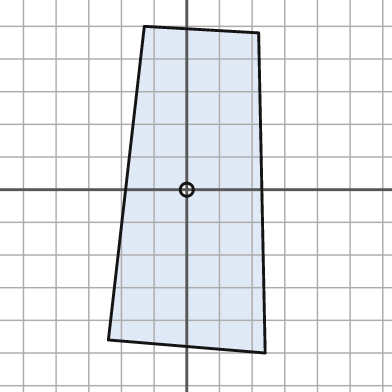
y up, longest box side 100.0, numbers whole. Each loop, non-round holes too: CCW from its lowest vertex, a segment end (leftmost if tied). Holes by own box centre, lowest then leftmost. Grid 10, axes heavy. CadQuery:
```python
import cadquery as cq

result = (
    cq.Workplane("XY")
    .moveTo(24.0, -50.0)
    .lineTo(22.0, 48.0)
    .lineTo(-13.0, 50.0)
    .lineTo(-24.0, -46.0)
    .close()
    .moveTo(0.0, 0.0)
    .circle(2.0)
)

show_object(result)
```